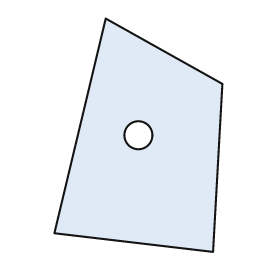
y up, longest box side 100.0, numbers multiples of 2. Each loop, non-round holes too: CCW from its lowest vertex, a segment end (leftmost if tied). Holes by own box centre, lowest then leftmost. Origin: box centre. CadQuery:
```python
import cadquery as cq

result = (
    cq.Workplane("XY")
    .moveTo(32.0, -50.0)
    .lineTo(36.0, 22.0)
    .lineTo(-14.0, 50.0)
    .lineTo(-36.0, -42.0)
    .close()
    .moveTo(0.0, 0.0)
    .circle(6.0)
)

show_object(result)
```